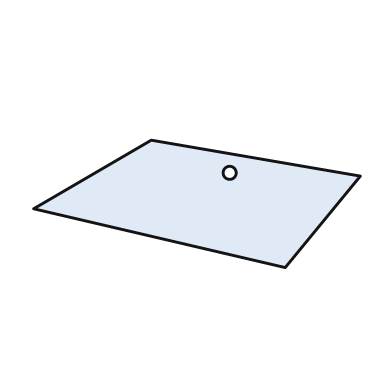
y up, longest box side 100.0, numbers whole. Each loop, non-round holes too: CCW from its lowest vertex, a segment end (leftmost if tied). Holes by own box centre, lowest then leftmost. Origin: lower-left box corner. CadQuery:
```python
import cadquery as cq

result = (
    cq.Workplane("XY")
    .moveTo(77.0, 0.0)
    .lineTo(100.0, 28.0)
    .lineTo(36.0, 39.0)
    .lineTo(0.0, 18.0)
    .close()
    .moveTo(60.0, 29.0)
    .circle(2.0)
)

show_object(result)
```